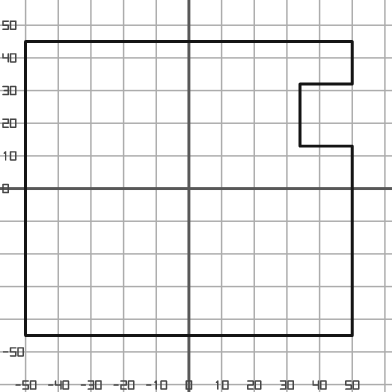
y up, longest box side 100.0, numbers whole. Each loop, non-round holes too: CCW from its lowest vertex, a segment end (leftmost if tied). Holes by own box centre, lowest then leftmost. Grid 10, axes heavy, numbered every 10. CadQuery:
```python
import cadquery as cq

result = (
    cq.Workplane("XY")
    .moveTo(-50.0, -45.0)
    .lineTo(50.0, -45.0)
    .lineTo(50.0, 13.0)
    .lineTo(34.0, 13.0)
    .lineTo(34.0, 32.0)
    .lineTo(50.0, 32.0)
    .lineTo(50.0, 45.0)
    .lineTo(-50.0, 45.0)
    .close()
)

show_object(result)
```